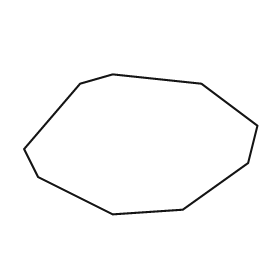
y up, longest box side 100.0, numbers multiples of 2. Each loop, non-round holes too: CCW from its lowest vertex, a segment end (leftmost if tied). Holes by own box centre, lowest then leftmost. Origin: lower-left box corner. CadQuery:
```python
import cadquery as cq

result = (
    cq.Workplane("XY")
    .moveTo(38.0, 0.0)
    .lineTo(68.0, 2.0)
    .lineTo(96.0, 22.0)
    .lineTo(100.0, 38.0)
    .lineTo(76.0, 56.0)
    .lineTo(38.0, 60.0)
    .lineTo(24.0, 56.0)
    .lineTo(0.0, 28.0)
    .lineTo(6.0, 16.0)
    .close()
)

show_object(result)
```